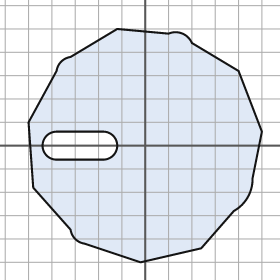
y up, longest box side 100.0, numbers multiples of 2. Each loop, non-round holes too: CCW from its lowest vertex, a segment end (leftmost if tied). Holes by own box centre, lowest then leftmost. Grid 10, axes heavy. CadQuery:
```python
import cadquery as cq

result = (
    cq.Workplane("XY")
    .moveTo(-2.0, -50.0)
    .lineTo(24.0, -44.0)
    .lineTo(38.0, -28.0)
    .threePointArc((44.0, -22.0), (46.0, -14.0))
    .lineTo(50.0, 6.0)
    .lineTo(40.0, 32.0)
    .lineTo(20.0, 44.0)
    .threePointArc((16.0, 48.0), (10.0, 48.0))
    .lineTo(-12.0, 50.0)
    .lineTo(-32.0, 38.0)
    .threePointArc((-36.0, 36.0), (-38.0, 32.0))
    .lineTo(-50.0, 10.0)
    .lineTo(-48.0, -18.0)
    .lineTo(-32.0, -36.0)
    .threePointArc((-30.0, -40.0), (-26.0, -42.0))
    .close()
    .moveTo(-38.0, -6.0)
    .lineTo(-18.0, -6.0)
    .threePointArc((-12.0, 0.0), (-18.0, 6.0))
    .lineTo(-38.0, 6.0)
    .threePointArc((-44.0, 0.0), (-38.0, -6.0))
    .close()
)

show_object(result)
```